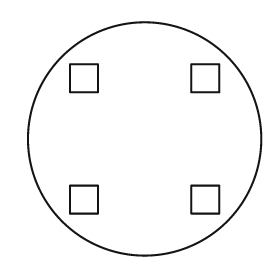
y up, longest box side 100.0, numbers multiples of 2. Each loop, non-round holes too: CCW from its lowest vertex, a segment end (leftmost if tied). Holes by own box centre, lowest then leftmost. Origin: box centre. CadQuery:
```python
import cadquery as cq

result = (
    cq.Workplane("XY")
    .moveTo(0.0, 0.0)
    .circle(50.0)
    .moveTo(-32.0, -32.0)
    .lineTo(-20.0, -32.0)
    .lineTo(-20.0, -20.0)
    .lineTo(-32.0, -20.0)
    .close()
    .moveTo(20.0, -32.0)
    .lineTo(32.0, -32.0)
    .lineTo(32.0, -20.0)
    .lineTo(20.0, -20.0)
    .close()
    .moveTo(-32.0, 20.0)
    .lineTo(-20.0, 20.0)
    .lineTo(-20.0, 32.0)
    .lineTo(-32.0, 32.0)
    .close()
    .moveTo(20.0, 20.0)
    .lineTo(32.0, 20.0)
    .lineTo(32.0, 32.0)
    .lineTo(20.0, 32.0)
    .close()
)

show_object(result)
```